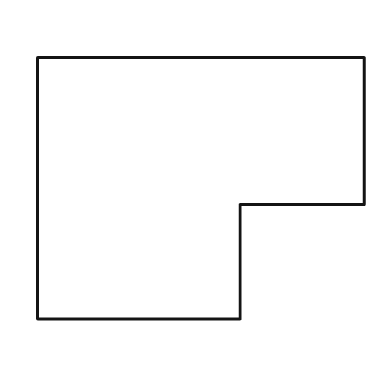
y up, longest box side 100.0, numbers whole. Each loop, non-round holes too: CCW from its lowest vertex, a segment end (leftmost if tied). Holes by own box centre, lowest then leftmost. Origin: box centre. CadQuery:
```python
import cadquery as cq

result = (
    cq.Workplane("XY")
    .moveTo(-50.0, -40.0)
    .lineTo(12.0, -40.0)
    .lineTo(12.0, -5.0)
    .lineTo(50.0, -5.0)
    .lineTo(50.0, 40.0)
    .lineTo(-50.0, 40.0)
    .close()
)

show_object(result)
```